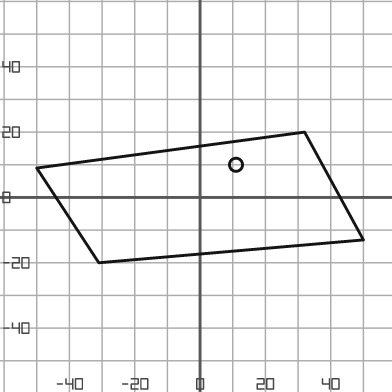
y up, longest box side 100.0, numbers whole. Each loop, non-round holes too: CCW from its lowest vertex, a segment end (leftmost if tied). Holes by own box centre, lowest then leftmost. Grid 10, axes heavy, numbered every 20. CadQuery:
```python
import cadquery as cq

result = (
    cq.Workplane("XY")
    .moveTo(-31.0, -20.0)
    .lineTo(50.0, -13.0)
    .lineTo(32.0, 20.0)
    .lineTo(-50.0, 9.0)
    .close()
    .moveTo(11.0, 10.0)
    .circle(2.0)
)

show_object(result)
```